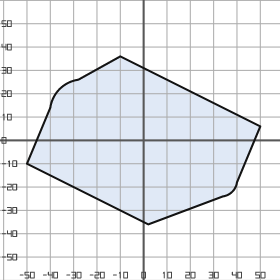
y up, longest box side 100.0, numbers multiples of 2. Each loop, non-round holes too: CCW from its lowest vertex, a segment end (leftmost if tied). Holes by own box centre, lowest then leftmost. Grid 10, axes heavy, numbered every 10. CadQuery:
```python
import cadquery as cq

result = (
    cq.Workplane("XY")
    .moveTo(2.0, -36.0)
    .lineTo(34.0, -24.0)
    .threePointArc((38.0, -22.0), (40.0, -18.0))
    .lineTo(50.0, 6.0)
    .lineTo(-10.0, 36.0)
    .lineTo(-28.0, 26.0)
    .threePointArc((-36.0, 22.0), (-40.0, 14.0))
    .lineTo(-50.0, -10.0)
    .close()
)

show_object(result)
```